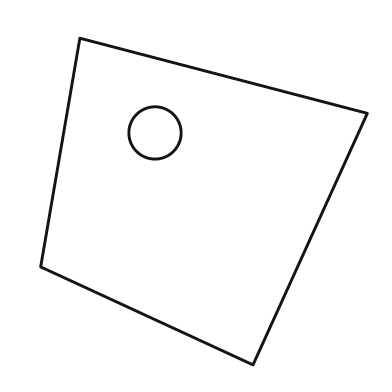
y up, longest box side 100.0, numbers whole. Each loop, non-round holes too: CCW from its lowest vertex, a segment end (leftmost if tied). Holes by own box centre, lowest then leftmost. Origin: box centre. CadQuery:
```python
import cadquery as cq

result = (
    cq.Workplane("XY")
    .moveTo(15.0, -50.0)
    .lineTo(50.0, 27.0)
    .lineTo(-38.0, 50.0)
    .lineTo(-50.0, -20.0)
    .close()
    .moveTo(-15.0, 21.0)
    .circle(8.0)
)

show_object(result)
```